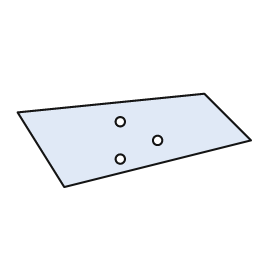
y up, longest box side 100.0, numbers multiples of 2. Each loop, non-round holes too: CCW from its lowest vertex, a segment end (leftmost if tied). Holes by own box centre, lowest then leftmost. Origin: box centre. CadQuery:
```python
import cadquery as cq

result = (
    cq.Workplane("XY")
    .moveTo(-30.0, -20.0)
    .lineTo(50.0, 0.0)
    .lineTo(30.0, 20.0)
    .lineTo(-50.0, 12.0)
    .close()
    .moveTo(-6.0, -8.0)
    .circle(2.0)
    .moveTo(10.0, 0.0)
    .circle(2.0)
    .moveTo(-6.0, 8.0)
    .circle(2.0)
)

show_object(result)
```